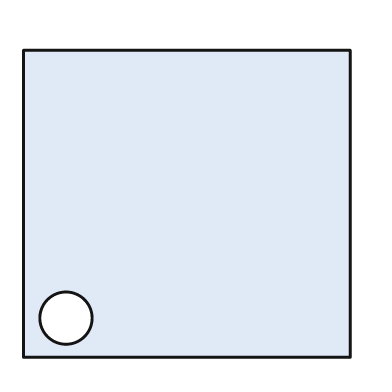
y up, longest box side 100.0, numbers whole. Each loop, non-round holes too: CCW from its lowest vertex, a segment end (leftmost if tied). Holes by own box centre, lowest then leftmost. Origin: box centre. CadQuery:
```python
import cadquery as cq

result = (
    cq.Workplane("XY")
    .moveTo(-50.0, -47.0)
    .lineTo(50.0, -47.0)
    .lineTo(50.0, 47.0)
    .lineTo(-50.0, 47.0)
    .close()
    .moveTo(-37.0, -35.0)
    .circle(8.0)
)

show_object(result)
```